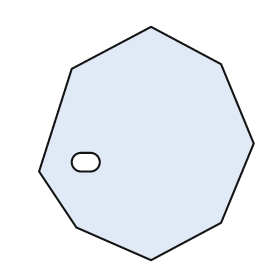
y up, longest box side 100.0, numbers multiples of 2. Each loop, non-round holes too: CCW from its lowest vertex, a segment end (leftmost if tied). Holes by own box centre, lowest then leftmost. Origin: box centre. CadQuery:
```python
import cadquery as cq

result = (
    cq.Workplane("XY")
    .moveTo(2.0, -50.0)
    .lineTo(32.0, -34.0)
    .lineTo(46.0, 0.0)
    .lineTo(32.0, 34.0)
    .lineTo(2.0, 50.0)
    .lineTo(-32.0, 32.0)
    .lineTo(-46.0, -12.0)
    .lineTo(-30.0, -36.0)
    .close()
    .moveTo(-28.0, -12.0)
    .lineTo(-24.0, -12.0)
    .threePointArc((-20.0, -8.0), (-24.0, -4.0))
    .lineTo(-28.0, -4.0)
    .threePointArc((-32.0, -8.0), (-28.0, -12.0))
    .close()
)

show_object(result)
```